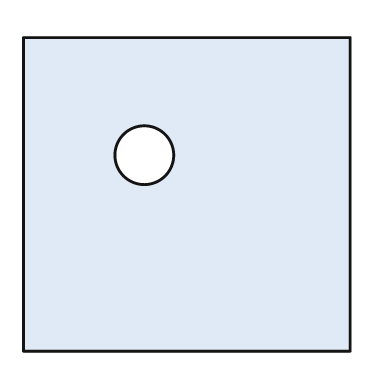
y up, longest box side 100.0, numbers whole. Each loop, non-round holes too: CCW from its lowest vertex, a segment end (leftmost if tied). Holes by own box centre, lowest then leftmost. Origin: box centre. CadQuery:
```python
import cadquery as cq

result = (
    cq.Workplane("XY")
    .moveTo(-50.0, -48.0)
    .lineTo(50.0, -48.0)
    .lineTo(50.0, 48.0)
    .lineTo(-50.0, 48.0)
    .close()
    .moveTo(-13.0, 12.0)
    .circle(9.0)
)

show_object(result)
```